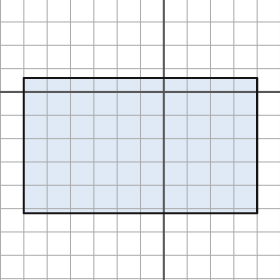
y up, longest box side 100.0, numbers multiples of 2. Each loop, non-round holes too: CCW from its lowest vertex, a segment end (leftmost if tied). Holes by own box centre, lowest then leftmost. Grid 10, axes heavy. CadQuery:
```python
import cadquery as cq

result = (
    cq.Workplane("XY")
    .moveTo(-60.0, -52.0)
    .lineTo(40.0, -52.0)
    .lineTo(40.0, 6.0)
    .lineTo(-60.0, 6.0)
    .close()
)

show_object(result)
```